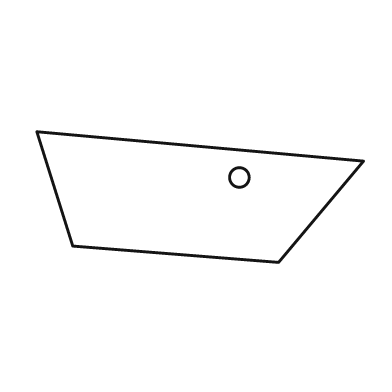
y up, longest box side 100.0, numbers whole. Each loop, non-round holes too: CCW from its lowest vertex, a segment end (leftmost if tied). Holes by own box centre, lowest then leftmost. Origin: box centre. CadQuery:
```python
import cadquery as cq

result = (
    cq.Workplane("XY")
    .moveTo(24.0, -20.0)
    .lineTo(50.0, 11.0)
    .lineTo(-50.0, 20.0)
    .lineTo(-39.0, -15.0)
    .close()
    .moveTo(12.0, 6.0)
    .circle(3.0)
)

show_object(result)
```